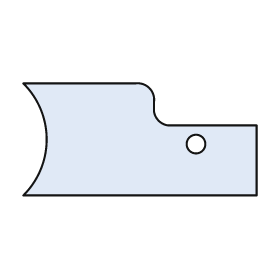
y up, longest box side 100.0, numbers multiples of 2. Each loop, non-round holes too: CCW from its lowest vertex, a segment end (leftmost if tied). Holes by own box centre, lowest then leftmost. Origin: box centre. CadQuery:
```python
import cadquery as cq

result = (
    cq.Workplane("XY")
    .moveTo(-50.0, -24.0)
    .lineTo(50.0, -24.0)
    .lineTo(50.0, 6.0)
    .lineTo(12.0, 6.0)
    .threePointArc((8.0, 8.0), (6.0, 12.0))
    .lineTo(6.0, 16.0)
    .threePointArc((4.0, 22.0), (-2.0, 24.0))
    .lineTo(-50.0, 24.0)
    .threePointArc((-40.0, 0.0), (-50.0, -24.0))
    .close()
    .moveTo(24.0, -2.0)
    .circle(4.0)
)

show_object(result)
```